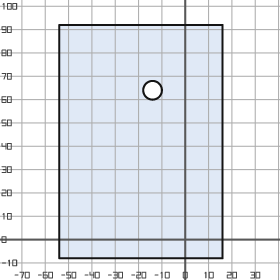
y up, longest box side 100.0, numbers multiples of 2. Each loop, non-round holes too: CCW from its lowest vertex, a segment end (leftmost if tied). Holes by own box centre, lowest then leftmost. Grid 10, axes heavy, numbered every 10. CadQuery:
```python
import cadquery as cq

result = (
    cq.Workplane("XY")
    .moveTo(-54.0, -8.0)
    .lineTo(16.0, -8.0)
    .lineTo(16.0, 92.0)
    .lineTo(-54.0, 92.0)
    .close()
    .moveTo(-14.0, 64.0)
    .circle(4.0)
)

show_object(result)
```